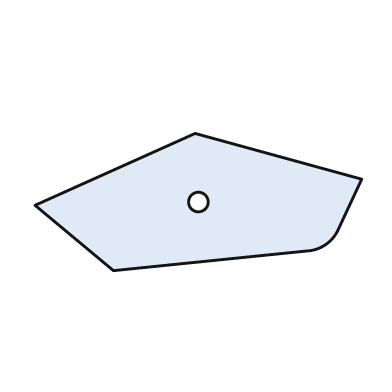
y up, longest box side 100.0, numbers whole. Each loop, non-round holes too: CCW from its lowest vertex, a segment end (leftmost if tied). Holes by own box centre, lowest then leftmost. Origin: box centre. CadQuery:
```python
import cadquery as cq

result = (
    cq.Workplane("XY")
    .moveTo(-26.0, -21.0)
    .lineTo(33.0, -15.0)
    .threePointArc((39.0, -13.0), (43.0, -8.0))
    .lineTo(50.0, 7.0)
    .lineTo(-1.0, 21.0)
    .lineTo(-50.0, -1.0)
    .close()
    .moveTo(0.0, 0.0)
    .circle(3.0)
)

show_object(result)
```